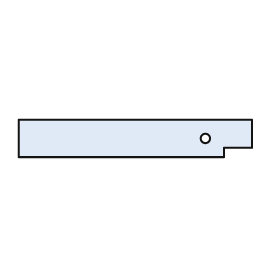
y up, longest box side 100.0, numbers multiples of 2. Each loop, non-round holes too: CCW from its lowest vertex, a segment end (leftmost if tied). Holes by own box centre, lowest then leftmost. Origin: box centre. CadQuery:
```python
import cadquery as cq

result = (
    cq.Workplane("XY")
    .moveTo(-50.0, -8.0)
    .lineTo(38.0, -8.0)
    .lineTo(38.0, -4.0)
    .lineTo(50.0, -4.0)
    .lineTo(50.0, 8.0)
    .lineTo(-50.0, 8.0)
    .close()
    .moveTo(30.0, 0.0)
    .circle(2.0)
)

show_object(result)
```